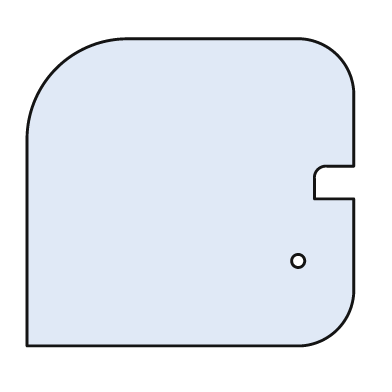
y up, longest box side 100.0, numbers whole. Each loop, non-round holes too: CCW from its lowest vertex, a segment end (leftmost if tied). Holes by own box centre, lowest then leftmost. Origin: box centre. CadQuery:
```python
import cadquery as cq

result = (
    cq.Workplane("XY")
    .moveTo(-50.0, -47.0)
    .lineTo(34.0, -47.0)
    .threePointArc((45.0, -42.0), (50.0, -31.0))
    .lineTo(50.0, -2.0)
    .lineTo(38.0, -2.0)
    .lineTo(38.0, 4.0)
    .threePointArc((39.0, 7.0), (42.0, 8.0))
    .lineTo(50.0, 8.0)
    .lineTo(50.0, 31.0)
    .threePointArc((45.0, 42.0), (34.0, 47.0))
    .lineTo(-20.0, 47.0)
    .threePointArc((-41.0, 38.0), (-50.0, 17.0))
    .close()
    .moveTo(33.0, -21.0)
    .circle(2.0)
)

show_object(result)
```